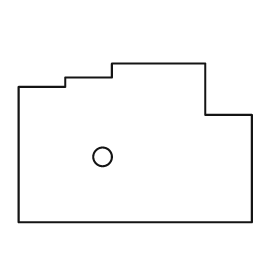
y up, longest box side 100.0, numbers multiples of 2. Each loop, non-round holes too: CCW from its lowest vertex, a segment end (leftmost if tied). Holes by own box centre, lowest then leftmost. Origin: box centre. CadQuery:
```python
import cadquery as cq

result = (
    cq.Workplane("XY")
    .moveTo(-50.0, -34.0)
    .lineTo(50.0, -34.0)
    .lineTo(50.0, 12.0)
    .lineTo(30.0, 12.0)
    .lineTo(30.0, 34.0)
    .lineTo(-10.0, 34.0)
    .lineTo(-10.0, 28.0)
    .lineTo(-30.0, 28.0)
    .lineTo(-30.0, 24.0)
    .lineTo(-50.0, 24.0)
    .close()
    .moveTo(-14.0, -6.0)
    .circle(4.0)
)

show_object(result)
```